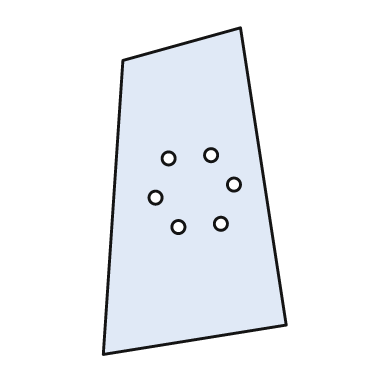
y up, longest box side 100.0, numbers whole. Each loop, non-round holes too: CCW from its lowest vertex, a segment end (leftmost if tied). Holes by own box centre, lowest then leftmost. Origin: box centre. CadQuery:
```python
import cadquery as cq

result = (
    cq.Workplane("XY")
    .moveTo(-28.0, -50.0)
    .lineTo(28.0, -41.0)
    .lineTo(14.0, 50.0)
    .lineTo(-22.0, 40.0)
    .close()
    .moveTo(-5.0, -11.0)
    .circle(2.0)
    .moveTo(8.0, -10.0)
    .circle(2.0)
    .moveTo(-12.0, -2.0)
    .circle(2.0)
    .moveTo(12.0, 2.0)
    .circle(2.0)
    .moveTo(-8.0, 10.0)
    .circle(2.0)
    .moveTo(5.0, 11.0)
    .circle(2.0)
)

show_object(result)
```